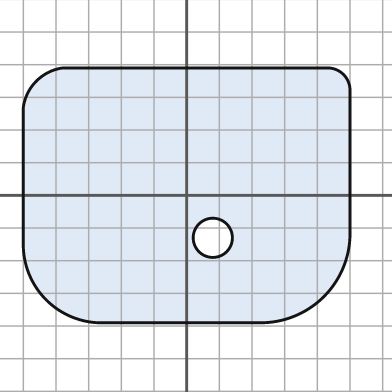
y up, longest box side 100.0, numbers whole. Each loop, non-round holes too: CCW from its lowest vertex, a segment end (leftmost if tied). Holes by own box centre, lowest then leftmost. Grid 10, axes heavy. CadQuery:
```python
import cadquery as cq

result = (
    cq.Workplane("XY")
    .moveTo(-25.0, -39.0)
    .lineTo(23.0, -39.0)
    .threePointArc((42.0, -31.0), (50.0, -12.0))
    .lineTo(50.0, 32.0)
    .threePointArc((48.0, 37.0), (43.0, 39.0))
    .lineTo(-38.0, 39.0)
    .threePointArc((-46.0, 35.0), (-50.0, 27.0))
    .lineTo(-50.0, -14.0)
    .threePointArc((-43.0, -32.0), (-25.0, -39.0))
    .close()
    .moveTo(8.0, -13.0)
    .circle(6.0)
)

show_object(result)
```